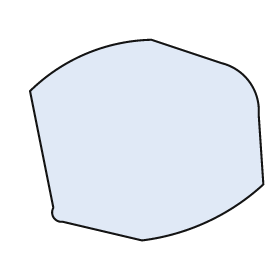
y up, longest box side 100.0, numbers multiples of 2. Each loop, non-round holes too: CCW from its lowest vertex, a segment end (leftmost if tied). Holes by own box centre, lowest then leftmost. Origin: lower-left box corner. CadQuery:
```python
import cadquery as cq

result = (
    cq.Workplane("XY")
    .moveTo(48.0, 0.0)
    .threePointArc((76.0, 8.0), (100.0, 24.0))
    .lineTo(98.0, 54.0)
    .threePointArc((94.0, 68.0), (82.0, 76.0))
    .lineTo(52.0, 86.0)
    .threePointArc((24.0, 80.0), (0.0, 64.0))
    .lineTo(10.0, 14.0)
    .threePointArc((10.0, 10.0), (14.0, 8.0))
    .close()
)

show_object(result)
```